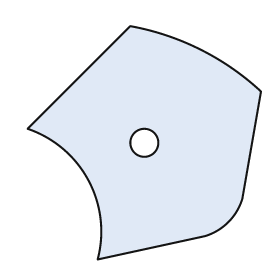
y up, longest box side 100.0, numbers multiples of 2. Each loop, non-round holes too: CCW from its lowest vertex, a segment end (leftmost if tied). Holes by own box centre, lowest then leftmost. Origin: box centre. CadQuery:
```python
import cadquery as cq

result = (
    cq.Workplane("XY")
    .moveTo(-20.0, -50.0)
    .lineTo(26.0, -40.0)
    .threePointArc((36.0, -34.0), (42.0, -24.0))
    .lineTo(50.0, 22.0)
    .threePointArc((24.0, 40.0), (-6.0, 50.0))
    .lineTo(-50.0, 6.0)
    .threePointArc((-24.0, -16.0), (-20.0, -50.0))
    .close()
    .moveTo(0.0, 0.0)
    .circle(6.0)
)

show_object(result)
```